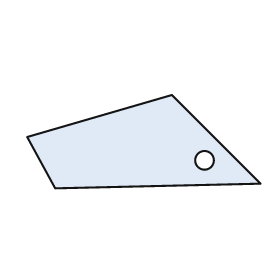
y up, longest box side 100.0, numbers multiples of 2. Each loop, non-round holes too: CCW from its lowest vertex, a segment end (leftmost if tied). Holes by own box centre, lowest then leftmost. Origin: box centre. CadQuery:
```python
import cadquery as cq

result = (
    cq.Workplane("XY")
    .moveTo(-38.0, -20.0)
    .lineTo(50.0, -18.0)
    .lineTo(12.0, 20.0)
    .lineTo(-50.0, 2.0)
    .close()
    .moveTo(26.0, -8.0)
    .circle(4.0)
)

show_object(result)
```